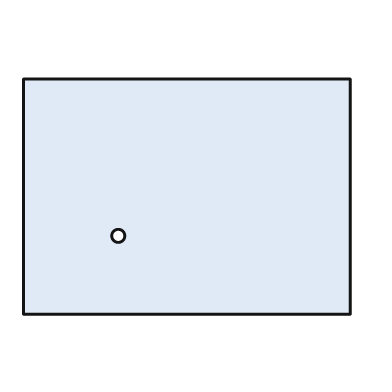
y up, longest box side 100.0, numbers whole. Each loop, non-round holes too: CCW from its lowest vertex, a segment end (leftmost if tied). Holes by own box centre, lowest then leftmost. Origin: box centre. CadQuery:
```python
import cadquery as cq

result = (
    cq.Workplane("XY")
    .moveTo(-50.0, -36.0)
    .lineTo(50.0, -36.0)
    .lineTo(50.0, 36.0)
    .lineTo(-50.0, 36.0)
    .close()
    .moveTo(-21.0, -12.0)
    .circle(2.0)
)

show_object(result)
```